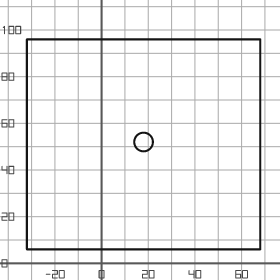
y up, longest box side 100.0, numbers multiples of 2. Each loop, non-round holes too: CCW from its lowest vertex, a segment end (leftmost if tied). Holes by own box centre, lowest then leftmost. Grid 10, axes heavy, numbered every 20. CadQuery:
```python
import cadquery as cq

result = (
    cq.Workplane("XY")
    .moveTo(-32.0, 6.0)
    .lineTo(68.0, 6.0)
    .lineTo(68.0, 96.0)
    .lineTo(-32.0, 96.0)
    .close()
    .moveTo(18.0, 52.0)
    .circle(4.0)
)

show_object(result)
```